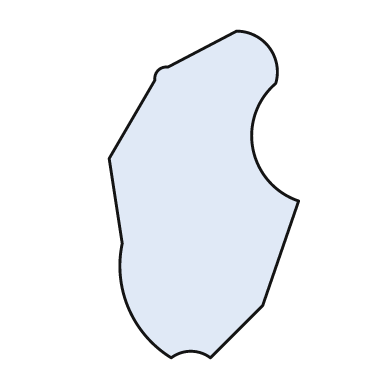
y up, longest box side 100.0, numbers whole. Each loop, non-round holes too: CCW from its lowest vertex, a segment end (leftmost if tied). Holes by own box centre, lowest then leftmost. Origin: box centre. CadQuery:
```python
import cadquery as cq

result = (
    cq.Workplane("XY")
    .moveTo(-10.0, -50.0)
    .threePointArc((-4.0, -48.0), (2.0, -50.0))
    .lineTo(18.0, -34.0)
    .lineTo(29.0, -2.0)
    .threePointArc((15.0, 14.0), (22.0, 34.0))
    .threePointArc((20.0, 45.0), (10.0, 50.0))
    .lineTo(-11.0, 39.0)
    .threePointArc((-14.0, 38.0), (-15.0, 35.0))
    .lineTo(-29.0, 11.0)
    .lineTo(-25.0, -15.0)
    .threePointArc((-23.0, -35.0), (-10.0, -50.0))
    .close()
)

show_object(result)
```